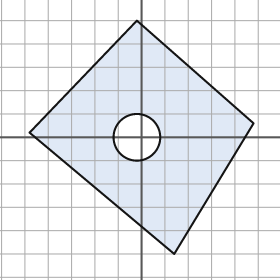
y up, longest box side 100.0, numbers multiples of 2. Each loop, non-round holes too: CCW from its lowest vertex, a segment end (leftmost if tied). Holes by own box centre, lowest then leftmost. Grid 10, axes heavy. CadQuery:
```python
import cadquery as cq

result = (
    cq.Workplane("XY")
    .moveTo(14.0, -50.0)
    .lineTo(48.0, 6.0)
    .lineTo(-2.0, 50.0)
    .lineTo(-48.0, 2.0)
    .close()
    .moveTo(-2.0, 0.0)
    .circle(10.0)
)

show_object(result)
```